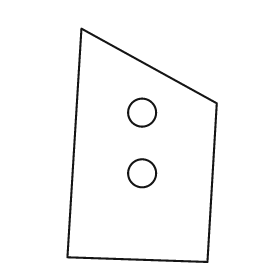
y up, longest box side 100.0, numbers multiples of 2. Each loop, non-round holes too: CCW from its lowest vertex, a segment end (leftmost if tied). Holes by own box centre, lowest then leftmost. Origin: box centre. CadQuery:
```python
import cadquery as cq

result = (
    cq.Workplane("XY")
    .moveTo(28.0, -50.0)
    .lineTo(32.0, 18.0)
    .lineTo(-26.0, 50.0)
    .lineTo(-32.0, -48.0)
    .close()
    .moveTo(0.0, -12.0)
    .circle(6.0)
    .moveTo(0.0, 14.0)
    .circle(6.0)
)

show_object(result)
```